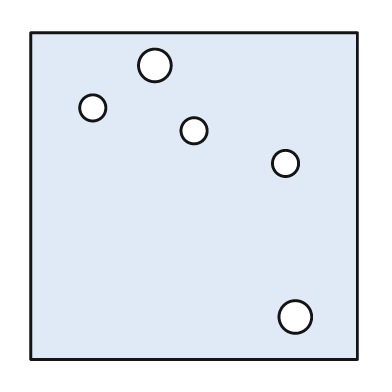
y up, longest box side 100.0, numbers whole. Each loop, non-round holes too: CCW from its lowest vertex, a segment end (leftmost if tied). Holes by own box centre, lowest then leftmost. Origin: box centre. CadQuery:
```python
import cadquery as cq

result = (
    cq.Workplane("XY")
    .moveTo(-50.0, -50.0)
    .lineTo(50.0, -50.0)
    .lineTo(50.0, 50.0)
    .lineTo(-50.0, 50.0)
    .close()
    .moveTo(31.0, -37.0)
    .circle(5.0)
    .moveTo(28.0, 10.0)
    .circle(4.0)
    .moveTo(0.0, 20.0)
    .circle(4.0)
    .moveTo(-31.0, 27.0)
    .circle(4.0)
    .moveTo(-12.0, 40.0)
    .circle(5.0)
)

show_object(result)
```